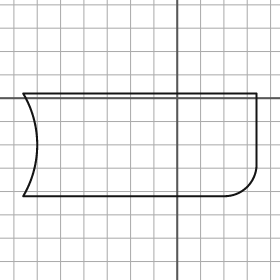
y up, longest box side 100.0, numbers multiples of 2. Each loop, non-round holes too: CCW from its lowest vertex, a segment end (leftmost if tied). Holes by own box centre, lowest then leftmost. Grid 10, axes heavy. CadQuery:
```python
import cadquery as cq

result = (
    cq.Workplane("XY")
    .moveTo(-66.0, -42.0)
    .lineTo(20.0, -42.0)
    .threePointArc((30.0, -38.0), (34.0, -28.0))
    .lineTo(34.0, 2.0)
    .lineTo(-66.0, 2.0)
    .threePointArc((-60.0, -20.0), (-66.0, -42.0))
    .close()
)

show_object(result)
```